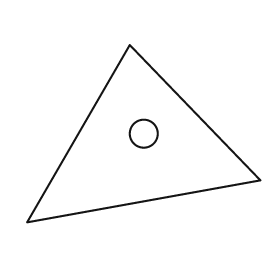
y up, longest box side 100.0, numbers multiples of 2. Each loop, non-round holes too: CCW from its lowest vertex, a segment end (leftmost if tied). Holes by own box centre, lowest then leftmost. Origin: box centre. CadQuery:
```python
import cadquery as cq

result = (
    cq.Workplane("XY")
    .moveTo(-50.0, -38.0)
    .lineTo(50.0, -20.0)
    .lineTo(-6.0, 38.0)
    .close()
    .moveTo(0.0, 0.0)
    .circle(6.0)
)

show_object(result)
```